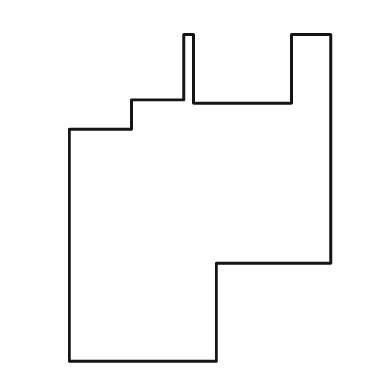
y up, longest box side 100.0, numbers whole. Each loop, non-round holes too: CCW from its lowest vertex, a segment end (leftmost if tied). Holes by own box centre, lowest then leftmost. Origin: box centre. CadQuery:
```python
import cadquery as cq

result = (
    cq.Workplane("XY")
    .moveTo(-40.0, -50.0)
    .lineTo(5.0, -50.0)
    .lineTo(5.0, -20.0)
    .lineTo(40.0, -20.0)
    .lineTo(40.0, 50.0)
    .lineTo(28.0, 50.0)
    .lineTo(28.0, 29.0)
    .lineTo(-2.0, 29.0)
    .lineTo(-2.0, 50.0)
    .lineTo(-5.0, 50.0)
    .lineTo(-5.0, 30.0)
    .lineTo(-21.0, 30.0)
    .lineTo(-21.0, 21.0)
    .lineTo(-40.0, 21.0)
    .close()
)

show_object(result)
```